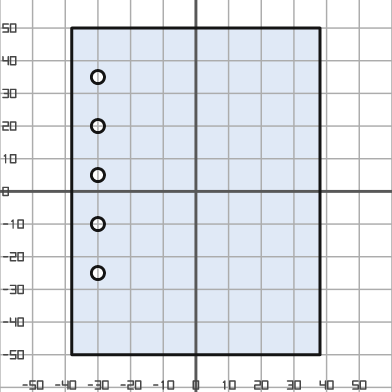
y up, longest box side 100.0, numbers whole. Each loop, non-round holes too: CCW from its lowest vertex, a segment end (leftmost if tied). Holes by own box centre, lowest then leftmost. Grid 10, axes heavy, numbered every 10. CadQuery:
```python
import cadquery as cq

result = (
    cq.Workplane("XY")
    .moveTo(-38.0, -50.0)
    .lineTo(38.0, -50.0)
    .lineTo(38.0, 50.0)
    .lineTo(-38.0, 50.0)
    .close()
    .moveTo(-30.0, -25.0)
    .circle(2.0)
    .moveTo(-30.0, -10.0)
    .circle(2.0)
    .moveTo(-30.0, 5.0)
    .circle(2.0)
    .moveTo(-30.0, 20.0)
    .circle(2.0)
    .moveTo(-30.0, 35.0)
    .circle(2.0)
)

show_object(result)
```